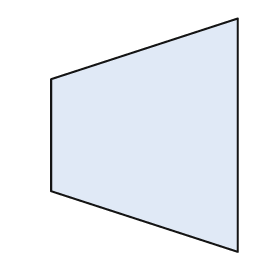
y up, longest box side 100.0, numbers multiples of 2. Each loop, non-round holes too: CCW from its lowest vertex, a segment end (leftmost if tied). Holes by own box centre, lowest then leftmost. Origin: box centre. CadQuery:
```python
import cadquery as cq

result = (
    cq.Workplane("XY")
    .moveTo(40.0, -50.0)
    .lineTo(40.0, 50.0)
    .lineTo(-40.0, 24.0)
    .lineTo(-40.0, -24.0)
    .close()
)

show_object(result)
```